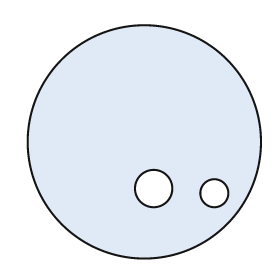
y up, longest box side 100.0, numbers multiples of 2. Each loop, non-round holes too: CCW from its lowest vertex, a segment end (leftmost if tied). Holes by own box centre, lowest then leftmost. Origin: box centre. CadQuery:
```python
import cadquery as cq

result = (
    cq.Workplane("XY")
    .moveTo(0.0, 0.0)
    .circle(50.0)
    .moveTo(30.0, -22.0)
    .circle(6.0)
    .moveTo(4.0, -20.0)
    .circle(8.0)
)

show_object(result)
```